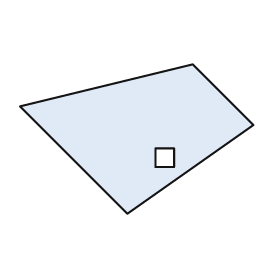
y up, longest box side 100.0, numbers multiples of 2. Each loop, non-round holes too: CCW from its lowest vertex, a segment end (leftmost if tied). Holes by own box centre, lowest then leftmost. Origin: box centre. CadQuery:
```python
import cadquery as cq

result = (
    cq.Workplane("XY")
    .moveTo(-4.0, -32.0)
    .lineTo(50.0, 6.0)
    .lineTo(24.0, 32.0)
    .lineTo(-50.0, 14.0)
    .close()
    .moveTo(8.0, -12.0)
    .lineTo(16.0, -12.0)
    .lineTo(16.0, -4.0)
    .lineTo(8.0, -4.0)
    .close()
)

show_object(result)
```